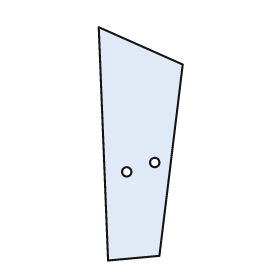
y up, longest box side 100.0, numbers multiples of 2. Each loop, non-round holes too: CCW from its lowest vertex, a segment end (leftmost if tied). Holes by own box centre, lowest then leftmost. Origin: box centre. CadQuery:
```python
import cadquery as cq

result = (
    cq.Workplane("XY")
    .moveTo(-14.0, -50.0)
    .lineTo(8.0, -48.0)
    .lineTo(18.0, 34.0)
    .lineTo(-18.0, 50.0)
    .close()
    .moveTo(-6.0, -12.0)
    .circle(2.0)
    .moveTo(6.0, -8.0)
    .circle(2.0)
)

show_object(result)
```